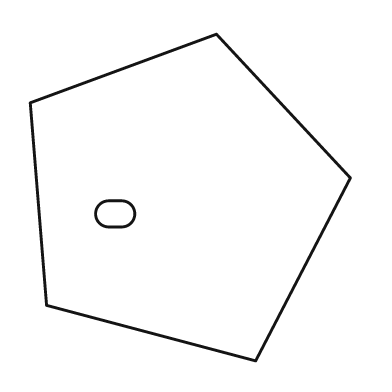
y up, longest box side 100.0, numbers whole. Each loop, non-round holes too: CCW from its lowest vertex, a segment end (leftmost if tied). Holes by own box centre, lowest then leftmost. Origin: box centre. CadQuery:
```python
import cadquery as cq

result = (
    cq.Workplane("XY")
    .moveTo(20.0, -50.0)
    .lineTo(49.0, 6.0)
    .lineTo(8.0, 50.0)
    .lineTo(-49.0, 29.0)
    .lineTo(-44.0, -33.0)
    .close()
    .moveTo(-25.0, -9.0)
    .lineTo(-21.0, -9.0)
    .threePointArc((-17.0, -5.0), (-21.0, -1.0))
    .lineTo(-25.0, -1.0)
    .threePointArc((-29.0, -5.0), (-25.0, -9.0))
    .close()
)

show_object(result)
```